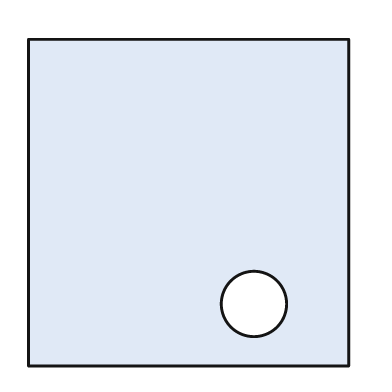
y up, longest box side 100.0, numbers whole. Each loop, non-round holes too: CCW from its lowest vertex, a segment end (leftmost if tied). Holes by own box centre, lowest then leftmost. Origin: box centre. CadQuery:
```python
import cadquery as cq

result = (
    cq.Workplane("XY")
    .moveTo(-49.0, -50.0)
    .lineTo(49.0, -50.0)
    .lineTo(49.0, 50.0)
    .lineTo(-49.0, 50.0)
    .close()
    .moveTo(20.0, -31.0)
    .circle(10.0)
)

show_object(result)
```